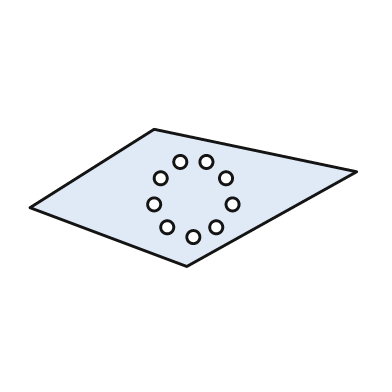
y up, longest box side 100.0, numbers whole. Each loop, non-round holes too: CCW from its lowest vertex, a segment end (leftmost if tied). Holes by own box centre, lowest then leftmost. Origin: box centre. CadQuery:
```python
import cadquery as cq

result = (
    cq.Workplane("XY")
    .moveTo(-2.0, -21.0)
    .lineTo(50.0, 8.0)
    .lineTo(-12.0, 21.0)
    .lineTo(-50.0, -3.0)
    .close()
    .moveTo(0.0, -12.0)
    .circle(2.0)
    .moveTo(-8.0, -9.0)
    .circle(2.0)
    .moveTo(7.0, -9.0)
    .circle(2.0)
    .moveTo(-12.0, -2.0)
    .circle(2.0)
    .moveTo(12.0, -2.0)
    .circle(2.0)
    .moveTo(-10.0, 6.0)
    .circle(2.0)
    .moveTo(10.0, 6.0)
    .circle(2.0)
    .moveTo(-4.0, 11.0)
    .circle(2.0)
    .moveTo(4.0, 11.0)
    .circle(2.0)
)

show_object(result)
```